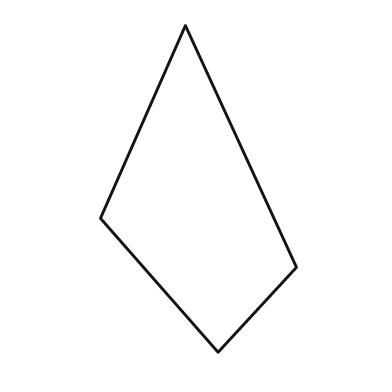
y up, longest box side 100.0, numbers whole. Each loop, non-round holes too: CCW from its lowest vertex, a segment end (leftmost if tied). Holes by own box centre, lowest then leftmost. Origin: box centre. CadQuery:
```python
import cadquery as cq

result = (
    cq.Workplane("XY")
    .moveTo(6.0, -50.0)
    .lineTo(30.0, -24.0)
    .lineTo(-4.0, 50.0)
    .lineTo(-30.0, -9.0)
    .close()
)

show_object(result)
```